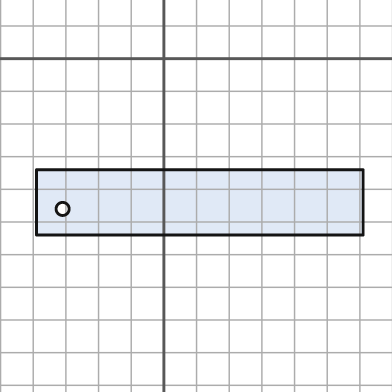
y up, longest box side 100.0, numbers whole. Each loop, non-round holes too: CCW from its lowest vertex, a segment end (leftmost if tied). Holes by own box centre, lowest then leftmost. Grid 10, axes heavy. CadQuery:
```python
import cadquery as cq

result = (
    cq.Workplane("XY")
    .moveTo(-39.0, -54.0)
    .lineTo(61.0, -54.0)
    .lineTo(61.0, -34.0)
    .lineTo(-39.0, -34.0)
    .close()
    .moveTo(-31.0, -46.0)
    .circle(2.0)
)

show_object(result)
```